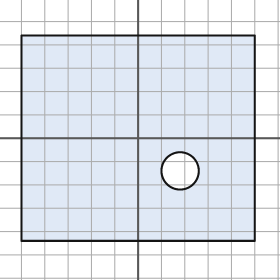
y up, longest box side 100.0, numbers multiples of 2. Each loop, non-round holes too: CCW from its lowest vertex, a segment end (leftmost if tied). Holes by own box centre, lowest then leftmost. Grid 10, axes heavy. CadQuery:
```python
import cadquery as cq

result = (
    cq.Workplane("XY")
    .moveTo(-50.0, -44.0)
    .lineTo(50.0, -44.0)
    .lineTo(50.0, 44.0)
    .lineTo(-50.0, 44.0)
    .close()
    .moveTo(18.0, -14.0)
    .circle(8.0)
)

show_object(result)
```